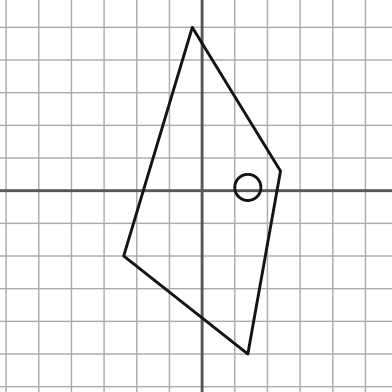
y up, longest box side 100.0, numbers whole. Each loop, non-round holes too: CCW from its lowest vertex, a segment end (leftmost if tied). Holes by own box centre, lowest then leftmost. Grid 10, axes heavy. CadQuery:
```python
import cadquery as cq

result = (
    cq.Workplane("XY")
    .moveTo(14.0, -50.0)
    .lineTo(24.0, 6.0)
    .lineTo(-3.0, 50.0)
    .lineTo(-24.0, -20.0)
    .close()
    .moveTo(14.0, 1.0)
    .circle(4.0)
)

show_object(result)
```